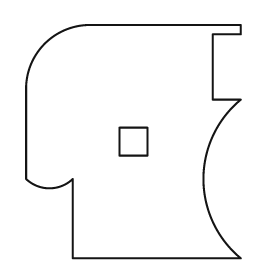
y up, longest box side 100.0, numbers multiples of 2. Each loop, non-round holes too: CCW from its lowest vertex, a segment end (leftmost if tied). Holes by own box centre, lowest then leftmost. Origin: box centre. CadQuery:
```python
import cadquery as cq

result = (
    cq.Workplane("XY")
    .moveTo(-26.0, -50.0)
    .lineTo(46.0, -50.0)
    .threePointArc((30.0, -16.0), (46.0, 18.0))
    .lineTo(34.0, 18.0)
    .lineTo(34.0, 46.0)
    .lineTo(46.0, 46.0)
    .lineTo(46.0, 50.0)
    .lineTo(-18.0, 50.0)
    .threePointArc((-38.0, 42.0), (-46.0, 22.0))
    .lineTo(-46.0, -16.0)
    .threePointArc((-36.0, -20.0), (-26.0, -16.0))
    .close()
    .moveTo(-6.0, -6.0)
    .lineTo(6.0, -6.0)
    .lineTo(6.0, 6.0)
    .lineTo(-6.0, 6.0)
    .close()
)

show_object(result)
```